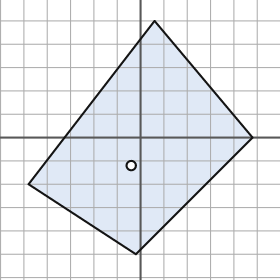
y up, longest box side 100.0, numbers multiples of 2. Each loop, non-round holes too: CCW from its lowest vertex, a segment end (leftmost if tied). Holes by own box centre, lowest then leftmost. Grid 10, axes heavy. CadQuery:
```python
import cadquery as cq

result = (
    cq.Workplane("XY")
    .moveTo(-2.0, -50.0)
    .lineTo(48.0, 0.0)
    .lineTo(6.0, 50.0)
    .lineTo(-48.0, -20.0)
    .close()
    .moveTo(-4.0, -12.0)
    .circle(2.0)
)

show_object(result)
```